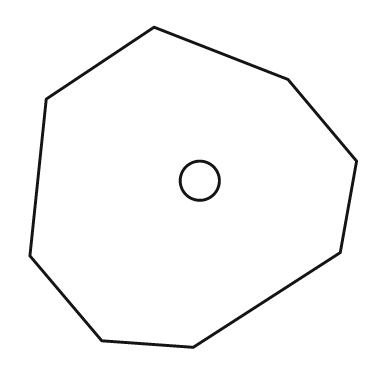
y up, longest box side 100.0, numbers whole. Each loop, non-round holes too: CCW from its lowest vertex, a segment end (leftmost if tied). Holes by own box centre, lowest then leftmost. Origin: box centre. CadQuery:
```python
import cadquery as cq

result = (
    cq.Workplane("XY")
    .moveTo(0.0, -49.0)
    .lineTo(45.0, -20.0)
    .lineTo(50.0, 8.0)
    .lineTo(29.0, 33.0)
    .lineTo(-12.0, 49.0)
    .lineTo(-45.0, 27.0)
    .lineTo(-50.0, -21.0)
    .lineTo(-28.0, -47.0)
    .close()
    .moveTo(2.0, 2.0)
    .circle(6.0)
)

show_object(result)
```